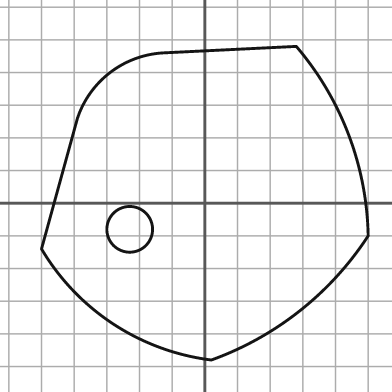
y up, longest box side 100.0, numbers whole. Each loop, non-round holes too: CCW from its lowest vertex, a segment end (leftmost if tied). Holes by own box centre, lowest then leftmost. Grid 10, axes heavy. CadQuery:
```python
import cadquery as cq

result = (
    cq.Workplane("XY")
    .moveTo(2.0, -48.0)
    .threePointArc((29.0, -33.0), (50.0, -10.0))
    .threePointArc((44.0, 21.0), (28.0, 48.0))
    .lineTo(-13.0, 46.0)
    .threePointArc((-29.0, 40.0), (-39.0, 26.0))
    .lineTo(-50.0, -14.0)
    .threePointArc((-28.0, -37.0), (2.0, -48.0))
    .close()
    .moveTo(-23.0, -8.0)
    .circle(7.0)
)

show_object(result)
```